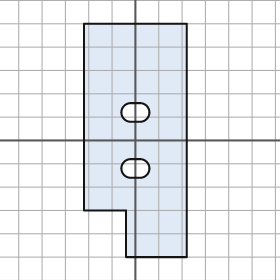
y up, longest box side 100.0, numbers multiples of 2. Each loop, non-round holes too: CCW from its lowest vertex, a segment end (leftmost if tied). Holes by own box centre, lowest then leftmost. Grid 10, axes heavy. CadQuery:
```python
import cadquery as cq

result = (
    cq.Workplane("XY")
    .moveTo(-4.0, -50.0)
    .lineTo(22.0, -50.0)
    .lineTo(22.0, 50.0)
    .lineTo(-22.0, 50.0)
    .lineTo(-22.0, -30.0)
    .lineTo(-4.0, -30.0)
    .close()
    .moveTo(-2.0, -16.0)
    .lineTo(2.0, -16.0)
    .threePointArc((6.0, -12.0), (2.0, -8.0))
    .lineTo(-2.0, -8.0)
    .threePointArc((-6.0, -12.0), (-2.0, -16.0))
    .close()
    .moveTo(-2.0, 8.0)
    .lineTo(2.0, 8.0)
    .threePointArc((6.0, 12.0), (2.0, 16.0))
    .lineTo(-2.0, 16.0)
    .threePointArc((-6.0, 12.0), (-2.0, 8.0))
    .close()
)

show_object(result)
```